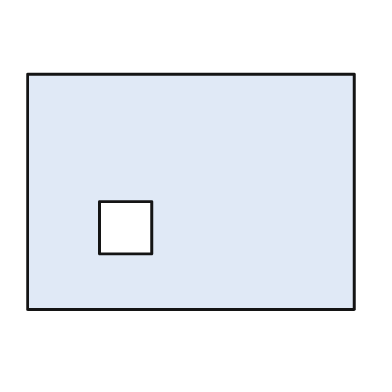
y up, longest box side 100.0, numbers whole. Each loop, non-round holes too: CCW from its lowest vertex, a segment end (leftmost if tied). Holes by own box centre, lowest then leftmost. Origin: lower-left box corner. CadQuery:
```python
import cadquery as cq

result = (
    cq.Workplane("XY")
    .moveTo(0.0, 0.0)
    .lineTo(100.0, 0.0)
    .lineTo(100.0, 72.0)
    .lineTo(0.0, 72.0)
    .close()
    .moveTo(22.0, 17.0)
    .lineTo(38.0, 17.0)
    .lineTo(38.0, 33.0)
    .lineTo(22.0, 33.0)
    .close()
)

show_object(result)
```